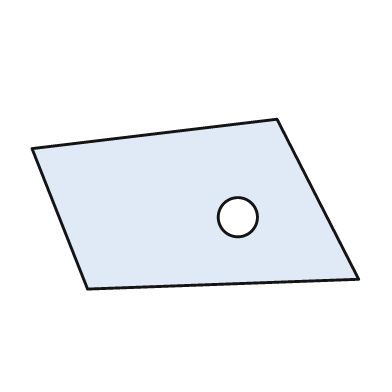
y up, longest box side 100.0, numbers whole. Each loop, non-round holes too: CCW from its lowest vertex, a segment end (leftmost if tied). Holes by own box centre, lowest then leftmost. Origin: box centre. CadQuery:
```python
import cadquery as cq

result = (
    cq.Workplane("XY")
    .moveTo(-33.0, -26.0)
    .lineTo(50.0, -23.0)
    .lineTo(25.0, 26.0)
    .lineTo(-50.0, 17.0)
    .close()
    .moveTo(13.0, -4.0)
    .circle(6.0)
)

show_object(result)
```